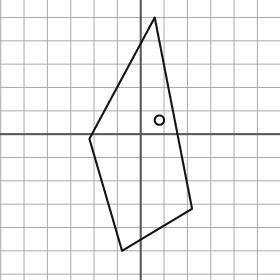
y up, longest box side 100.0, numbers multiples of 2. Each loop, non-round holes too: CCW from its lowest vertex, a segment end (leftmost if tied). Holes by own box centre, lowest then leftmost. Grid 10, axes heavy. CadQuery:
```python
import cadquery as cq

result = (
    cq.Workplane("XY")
    .moveTo(-8.0, -50.0)
    .lineTo(22.0, -32.0)
    .lineTo(6.0, 50.0)
    .lineTo(-22.0, -2.0)
    .close()
    .moveTo(8.0, 6.0)
    .circle(2.0)
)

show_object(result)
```